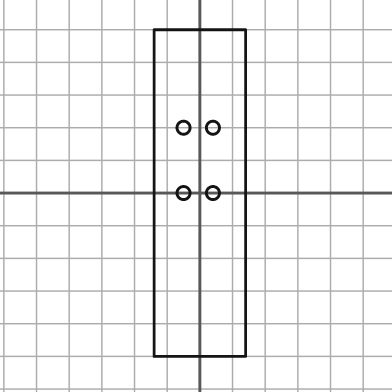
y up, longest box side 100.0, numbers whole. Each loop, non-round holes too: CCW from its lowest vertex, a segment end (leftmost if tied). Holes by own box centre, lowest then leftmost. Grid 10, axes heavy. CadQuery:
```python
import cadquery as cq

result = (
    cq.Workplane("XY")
    .moveTo(-14.0, -50.0)
    .lineTo(14.0, -50.0)
    .lineTo(14.0, 50.0)
    .lineTo(-14.0, 50.0)
    .close()
    .moveTo(-5.0, 0.0)
    .circle(2.0)
    .moveTo(4.0, 0.0)
    .circle(2.0)
    .moveTo(-5.0, 20.0)
    .circle(2.0)
    .moveTo(4.0, 20.0)
    .circle(2.0)
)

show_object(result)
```